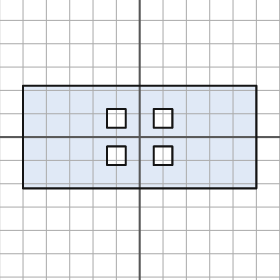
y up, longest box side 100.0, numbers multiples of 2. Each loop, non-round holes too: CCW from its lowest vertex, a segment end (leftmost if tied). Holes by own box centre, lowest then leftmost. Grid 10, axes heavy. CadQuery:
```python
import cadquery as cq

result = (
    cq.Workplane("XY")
    .moveTo(-50.0, -22.0)
    .lineTo(50.0, -22.0)
    .lineTo(50.0, 22.0)
    .lineTo(-50.0, 22.0)
    .close()
    .moveTo(-14.0, -12.0)
    .lineTo(-6.0, -12.0)
    .lineTo(-6.0, -4.0)
    .lineTo(-14.0, -4.0)
    .close()
    .moveTo(6.0, -12.0)
    .lineTo(14.0, -12.0)
    .lineTo(14.0, -4.0)
    .lineTo(6.0, -4.0)
    .close()
    .moveTo(-14.0, 4.0)
    .lineTo(-6.0, 4.0)
    .lineTo(-6.0, 12.0)
    .lineTo(-14.0, 12.0)
    .close()
    .moveTo(6.0, 4.0)
    .lineTo(14.0, 4.0)
    .lineTo(14.0, 12.0)
    .lineTo(6.0, 12.0)
    .close()
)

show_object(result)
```